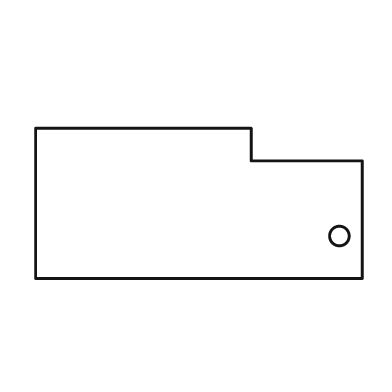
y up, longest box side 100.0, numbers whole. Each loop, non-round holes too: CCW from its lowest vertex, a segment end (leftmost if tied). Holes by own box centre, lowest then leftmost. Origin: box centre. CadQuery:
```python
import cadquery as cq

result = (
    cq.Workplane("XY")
    .moveTo(-50.0, -23.0)
    .lineTo(50.0, -23.0)
    .lineTo(50.0, 13.0)
    .lineTo(16.0, 13.0)
    .lineTo(16.0, 23.0)
    .lineTo(-50.0, 23.0)
    .close()
    .moveTo(43.0, -10.0)
    .circle(3.0)
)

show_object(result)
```